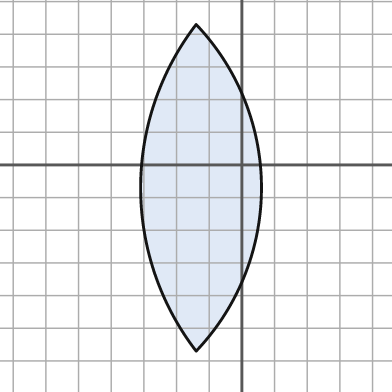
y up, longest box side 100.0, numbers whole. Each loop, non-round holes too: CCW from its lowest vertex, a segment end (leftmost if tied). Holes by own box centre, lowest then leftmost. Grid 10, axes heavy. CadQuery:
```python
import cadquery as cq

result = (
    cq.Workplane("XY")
    .moveTo(-14.0, -57.0)
    .threePointArc((6.0, -7.0), (-14.0, 43.0))
    .threePointArc((-31.0, -7.0), (-14.0, -57.0))
    .close()
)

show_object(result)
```